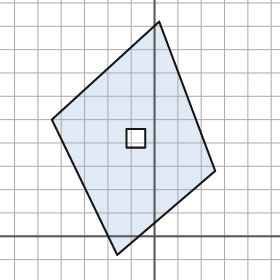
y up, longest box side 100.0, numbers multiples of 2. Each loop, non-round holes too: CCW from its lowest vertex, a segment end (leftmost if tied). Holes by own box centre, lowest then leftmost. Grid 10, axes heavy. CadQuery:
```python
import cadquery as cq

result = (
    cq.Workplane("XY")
    .moveTo(-16.0, -8.0)
    .lineTo(26.0, 28.0)
    .lineTo(2.0, 92.0)
    .lineTo(-44.0, 50.0)
    .close()
    .moveTo(-12.0, 38.0)
    .lineTo(-4.0, 38.0)
    .lineTo(-4.0, 46.0)
    .lineTo(-12.0, 46.0)
    .close()
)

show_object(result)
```